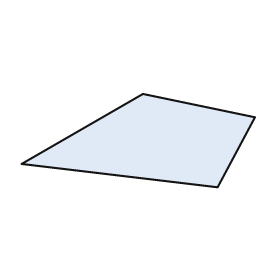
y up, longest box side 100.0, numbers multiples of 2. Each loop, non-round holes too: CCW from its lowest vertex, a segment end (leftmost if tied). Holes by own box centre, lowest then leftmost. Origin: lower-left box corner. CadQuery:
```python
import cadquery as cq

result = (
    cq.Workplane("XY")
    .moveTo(84.0, 0.0)
    .lineTo(100.0, 30.0)
    .lineTo(52.0, 40.0)
    .lineTo(0.0, 10.0)
    .close()
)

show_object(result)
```